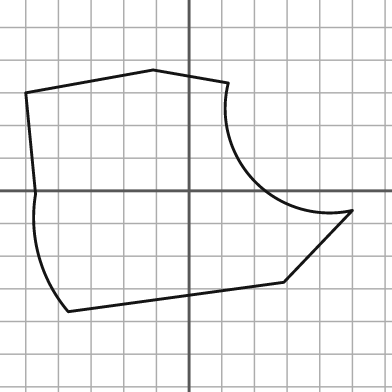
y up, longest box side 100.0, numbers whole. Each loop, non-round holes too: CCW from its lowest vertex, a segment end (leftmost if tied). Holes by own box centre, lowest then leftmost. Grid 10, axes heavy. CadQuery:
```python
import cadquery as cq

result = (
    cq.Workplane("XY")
    .moveTo(-37.0, -37.0)
    .lineTo(29.0, -28.0)
    .lineTo(50.0, -6.0)
    .threePointArc((20.0, 3.0), (12.0, 33.0))
    .lineTo(-11.0, 37.0)
    .lineTo(-50.0, 30.0)
    .lineTo(-47.0, -1.0)
    .threePointArc((-46.0, -20.0), (-37.0, -37.0))
    .close()
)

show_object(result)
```